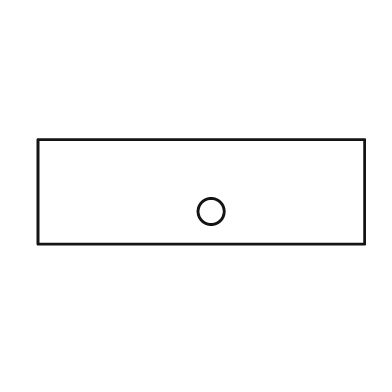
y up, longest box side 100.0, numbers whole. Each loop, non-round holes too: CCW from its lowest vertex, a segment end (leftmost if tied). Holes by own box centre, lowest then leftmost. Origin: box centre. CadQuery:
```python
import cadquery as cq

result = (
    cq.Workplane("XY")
    .moveTo(-50.0, -16.0)
    .lineTo(50.0, -16.0)
    .lineTo(50.0, 16.0)
    .lineTo(-50.0, 16.0)
    .close()
    .moveTo(3.0, -6.0)
    .circle(4.0)
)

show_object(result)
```